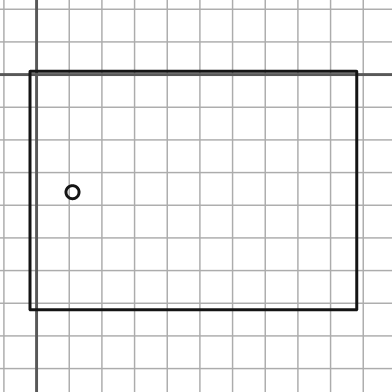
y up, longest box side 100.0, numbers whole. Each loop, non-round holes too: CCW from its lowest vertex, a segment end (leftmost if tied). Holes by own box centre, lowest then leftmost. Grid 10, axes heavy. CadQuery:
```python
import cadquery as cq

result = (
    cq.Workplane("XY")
    .moveTo(-2.0, -72.0)
    .lineTo(98.0, -72.0)
    .lineTo(98.0, 1.0)
    .lineTo(-2.0, 1.0)
    .close()
    .moveTo(11.0, -36.0)
    .circle(2.0)
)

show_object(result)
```